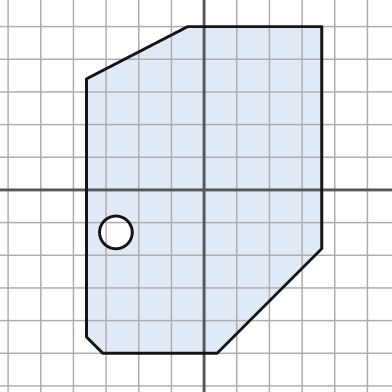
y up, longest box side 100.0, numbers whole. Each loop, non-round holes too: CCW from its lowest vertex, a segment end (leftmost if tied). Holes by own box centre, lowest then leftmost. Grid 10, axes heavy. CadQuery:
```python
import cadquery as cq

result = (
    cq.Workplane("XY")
    .moveTo(-31.0, -50.0)
    .lineTo(4.0, -50.0)
    .lineTo(36.0, -18.0)
    .lineTo(36.0, 50.0)
    .lineTo(-5.0, 50.0)
    .lineTo(-36.0, 34.0)
    .lineTo(-36.0, -45.0)
    .close()
    .moveTo(-27.0, -13.0)
    .circle(5.0)
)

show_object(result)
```